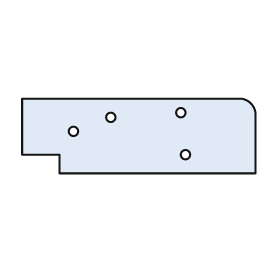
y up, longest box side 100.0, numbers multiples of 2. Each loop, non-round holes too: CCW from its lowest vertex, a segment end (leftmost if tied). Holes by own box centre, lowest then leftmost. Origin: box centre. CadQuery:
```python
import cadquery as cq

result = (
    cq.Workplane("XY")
    .moveTo(-34.0, -16.0)
    .lineTo(50.0, -16.0)
    .lineTo(50.0, 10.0)
    .threePointArc((48.0, 14.0), (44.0, 16.0))
    .lineTo(-50.0, 16.0)
    .lineTo(-50.0, -8.0)
    .lineTo(-34.0, -8.0)
    .close()
    .moveTo(20.0, -8.0)
    .circle(2.0)
    .moveTo(-28.0, 2.0)
    .circle(2.0)
    .moveTo(-12.0, 8.0)
    .circle(2.0)
    .moveTo(18.0, 10.0)
    .circle(2.0)
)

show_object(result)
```